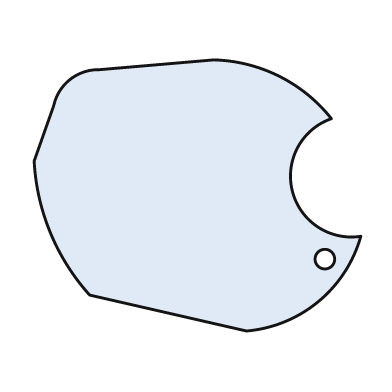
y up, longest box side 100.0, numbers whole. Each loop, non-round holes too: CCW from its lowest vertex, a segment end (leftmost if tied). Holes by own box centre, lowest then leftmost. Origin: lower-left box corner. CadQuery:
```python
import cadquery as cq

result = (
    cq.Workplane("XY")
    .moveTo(65.0, 0.0)
    .threePointArc((87.0, 9.0), (100.0, 29.0))
    .threePointArc((79.0, 43.0), (91.0, 65.0))
    .threePointArc((75.0, 78.0), (55.0, 83.0))
    .lineTo(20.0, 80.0)
    .threePointArc((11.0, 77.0), (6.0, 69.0))
    .lineTo(0.0, 52.0)
    .threePointArc((5.0, 30.0), (17.0, 11.0))
    .close()
    .moveTo(89.0, 22.0)
    .circle(3.0)
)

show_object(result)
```